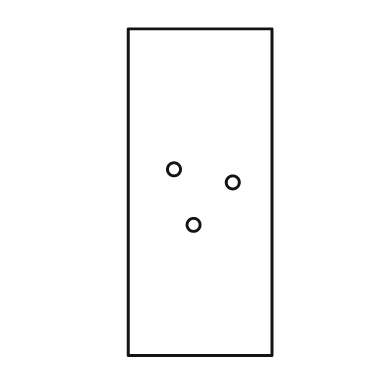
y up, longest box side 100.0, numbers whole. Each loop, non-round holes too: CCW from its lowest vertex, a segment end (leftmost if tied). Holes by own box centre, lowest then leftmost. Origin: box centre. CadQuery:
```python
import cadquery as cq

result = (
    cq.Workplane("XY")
    .moveTo(-22.0, -50.0)
    .lineTo(22.0, -50.0)
    .lineTo(22.0, 50.0)
    .lineTo(-22.0, 50.0)
    .close()
    .moveTo(-2.0, -10.0)
    .circle(2.0)
    .moveTo(10.0, 3.0)
    .circle(2.0)
    .moveTo(-8.0, 7.0)
    .circle(2.0)
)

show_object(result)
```